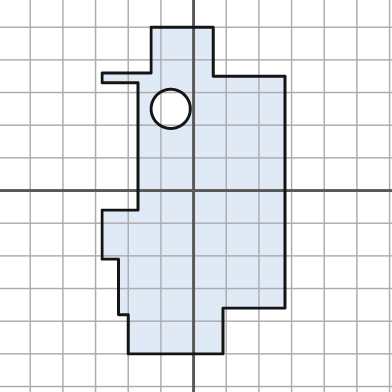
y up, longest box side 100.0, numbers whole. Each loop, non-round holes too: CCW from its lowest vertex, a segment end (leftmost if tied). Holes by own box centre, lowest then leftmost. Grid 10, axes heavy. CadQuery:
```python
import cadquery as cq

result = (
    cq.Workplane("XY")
    .moveTo(-20.0, -50.0)
    .lineTo(9.0, -50.0)
    .lineTo(9.0, -36.0)
    .lineTo(28.0, -36.0)
    .lineTo(28.0, 35.0)
    .lineTo(6.0, 35.0)
    .lineTo(6.0, 50.0)
    .lineTo(-13.0, 50.0)
    .lineTo(-13.0, 36.0)
    .lineTo(-28.0, 36.0)
    .lineTo(-28.0, 33.0)
    .lineTo(-17.0, 33.0)
    .lineTo(-17.0, -6.0)
    .lineTo(-28.0, -6.0)
    .lineTo(-28.0, -21.0)
    .lineTo(-23.0, -21.0)
    .lineTo(-23.0, -38.0)
    .lineTo(-20.0, -38.0)
    .close()
    .moveTo(-7.0, 25.0)
    .circle(6.0)
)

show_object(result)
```